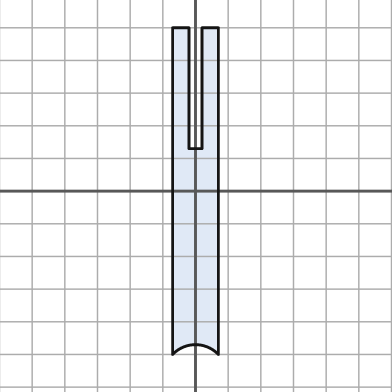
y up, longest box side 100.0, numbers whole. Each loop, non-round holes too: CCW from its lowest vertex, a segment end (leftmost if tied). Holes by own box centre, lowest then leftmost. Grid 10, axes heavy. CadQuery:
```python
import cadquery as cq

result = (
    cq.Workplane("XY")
    .moveTo(-7.0, -50.0)
    .threePointArc((0.0, -47.0), (7.0, -50.0))
    .lineTo(7.0, 50.0)
    .lineTo(2.0, 50.0)
    .lineTo(2.0, 13.0)
    .lineTo(-2.0, 13.0)
    .lineTo(-2.0, 50.0)
    .lineTo(-7.0, 50.0)
    .close()
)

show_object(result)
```